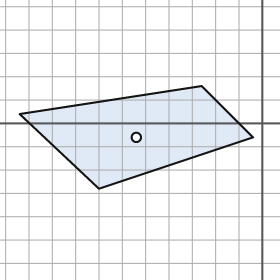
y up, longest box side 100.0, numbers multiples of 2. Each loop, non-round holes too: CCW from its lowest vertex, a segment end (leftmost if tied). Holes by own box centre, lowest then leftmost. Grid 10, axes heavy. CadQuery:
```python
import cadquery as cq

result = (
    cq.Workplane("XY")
    .moveTo(-70.0, -28.0)
    .lineTo(-4.0, -6.0)
    .lineTo(-26.0, 16.0)
    .lineTo(-104.0, 4.0)
    .close()
    .moveTo(-54.0, -6.0)
    .circle(2.0)
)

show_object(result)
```